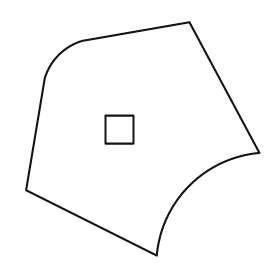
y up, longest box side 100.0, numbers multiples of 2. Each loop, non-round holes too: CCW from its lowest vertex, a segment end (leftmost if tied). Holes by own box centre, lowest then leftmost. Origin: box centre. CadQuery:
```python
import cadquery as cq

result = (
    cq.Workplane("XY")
    .moveTo(6.0, -50.0)
    .threePointArc((20.0, -20.0), (50.0, -6.0))
    .lineTo(20.0, 50.0)
    .lineTo(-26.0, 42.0)
    .threePointArc((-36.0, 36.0), (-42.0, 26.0))
    .lineTo(-50.0, -22.0)
    .close()
    .moveTo(-16.0, -2.0)
    .lineTo(-4.0, -2.0)
    .lineTo(-4.0, 10.0)
    .lineTo(-16.0, 10.0)
    .close()
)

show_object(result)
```